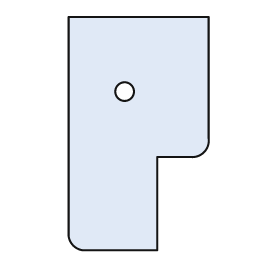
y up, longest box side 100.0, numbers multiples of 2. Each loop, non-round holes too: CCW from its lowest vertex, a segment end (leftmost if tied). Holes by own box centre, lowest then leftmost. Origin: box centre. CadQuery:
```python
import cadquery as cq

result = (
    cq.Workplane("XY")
    .moveTo(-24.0, -50.0)
    .lineTo(8.0, -50.0)
    .lineTo(8.0, -10.0)
    .lineTo(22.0, -10.0)
    .threePointArc((28.0, -8.0), (30.0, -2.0))
    .lineTo(30.0, 50.0)
    .lineTo(-30.0, 50.0)
    .lineTo(-30.0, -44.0)
    .threePointArc((-28.0, -48.0), (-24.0, -50.0))
    .close()
    .moveTo(-6.0, 18.0)
    .circle(4.0)
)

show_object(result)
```